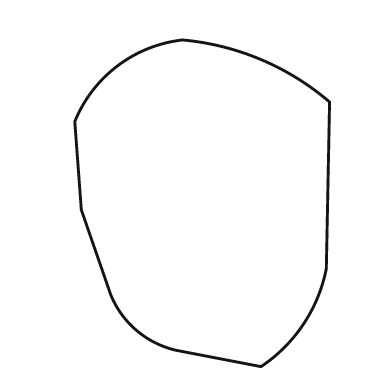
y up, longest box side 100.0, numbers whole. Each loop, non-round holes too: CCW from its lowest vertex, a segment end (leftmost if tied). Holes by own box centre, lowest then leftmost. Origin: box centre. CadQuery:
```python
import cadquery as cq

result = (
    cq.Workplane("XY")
    .moveTo(18.0, -50.0)
    .threePointArc((31.0, -37.0), (38.0, -20.0))
    .lineTo(39.0, 31.0)
    .threePointArc((18.0, 44.0), (-6.0, 50.0))
    .threePointArc((-26.0, 42.0), (-39.0, 25.0))
    .lineTo(-37.0, -2.0)
    .lineTo(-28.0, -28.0)
    .threePointArc((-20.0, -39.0), (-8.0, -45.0))
    .close()
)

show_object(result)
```